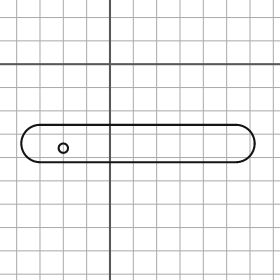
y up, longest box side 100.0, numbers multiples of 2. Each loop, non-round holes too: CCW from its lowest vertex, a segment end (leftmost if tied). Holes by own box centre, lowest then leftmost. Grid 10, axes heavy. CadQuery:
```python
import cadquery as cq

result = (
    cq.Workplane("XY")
    .moveTo(-30.0, -42.0)
    .lineTo(54.0, -42.0)
    .threePointArc((62.0, -34.0), (54.0, -26.0))
    .lineTo(-30.0, -26.0)
    .threePointArc((-38.0, -34.0), (-30.0, -42.0))
    .close()
    .moveTo(-20.0, -36.0)
    .circle(2.0)
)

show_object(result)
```